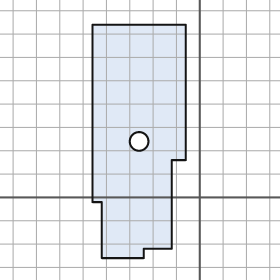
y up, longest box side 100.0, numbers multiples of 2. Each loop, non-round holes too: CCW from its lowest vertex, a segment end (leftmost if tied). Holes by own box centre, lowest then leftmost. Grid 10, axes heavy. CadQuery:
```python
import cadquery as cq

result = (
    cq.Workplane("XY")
    .moveTo(-42.0, -26.0)
    .lineTo(-24.0, -26.0)
    .lineTo(-24.0, -22.0)
    .lineTo(-12.0, -22.0)
    .lineTo(-12.0, 16.0)
    .lineTo(-6.0, 16.0)
    .lineTo(-6.0, 74.0)
    .lineTo(-46.0, 74.0)
    .lineTo(-46.0, -2.0)
    .lineTo(-42.0, -2.0)
    .close()
    .moveTo(-26.0, 24.0)
    .circle(4.0)
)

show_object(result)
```